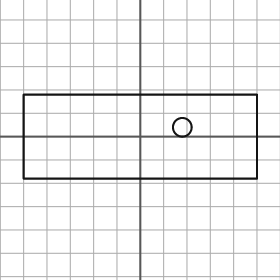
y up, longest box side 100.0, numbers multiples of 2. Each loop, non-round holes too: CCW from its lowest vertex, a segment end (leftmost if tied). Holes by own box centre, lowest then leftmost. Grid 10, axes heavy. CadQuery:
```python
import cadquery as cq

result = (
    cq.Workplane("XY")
    .moveTo(-50.0, -18.0)
    .lineTo(50.0, -18.0)
    .lineTo(50.0, 18.0)
    .lineTo(-50.0, 18.0)
    .close()
    .moveTo(18.0, 4.0)
    .circle(4.0)
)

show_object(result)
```